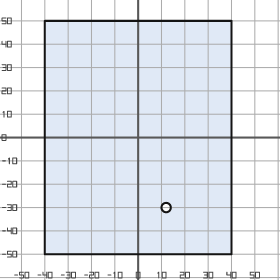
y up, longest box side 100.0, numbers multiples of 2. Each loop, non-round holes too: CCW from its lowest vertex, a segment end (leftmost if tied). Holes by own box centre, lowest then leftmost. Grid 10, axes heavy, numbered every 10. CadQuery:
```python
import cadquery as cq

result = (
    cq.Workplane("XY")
    .moveTo(-40.0, -50.0)
    .lineTo(40.0, -50.0)
    .lineTo(40.0, 50.0)
    .lineTo(-40.0, 50.0)
    .close()
    .moveTo(12.0, -30.0)
    .circle(2.0)
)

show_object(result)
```